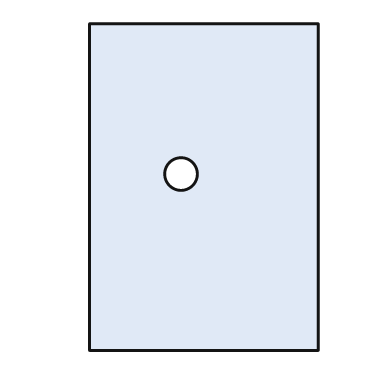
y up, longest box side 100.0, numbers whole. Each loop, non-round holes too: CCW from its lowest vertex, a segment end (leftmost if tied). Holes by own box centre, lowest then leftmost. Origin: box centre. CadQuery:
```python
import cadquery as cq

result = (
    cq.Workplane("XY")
    .moveTo(-35.0, -50.0)
    .lineTo(35.0, -50.0)
    .lineTo(35.0, 50.0)
    .lineTo(-35.0, 50.0)
    .close()
    .moveTo(-7.0, 4.0)
    .circle(5.0)
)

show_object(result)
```